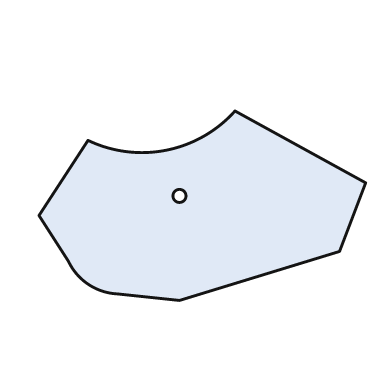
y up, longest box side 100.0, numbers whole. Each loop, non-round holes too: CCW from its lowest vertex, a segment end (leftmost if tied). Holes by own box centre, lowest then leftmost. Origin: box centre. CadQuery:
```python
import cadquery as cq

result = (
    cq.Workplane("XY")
    .moveTo(-7.0, -29.0)
    .lineTo(42.0, -14.0)
    .lineTo(50.0, 7.0)
    .lineTo(10.0, 29.0)
    .threePointArc((-11.0, 17.0), (-35.0, 20.0))
    .lineTo(-50.0, -3.0)
    .lineTo(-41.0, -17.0)
    .threePointArc((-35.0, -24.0), (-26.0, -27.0))
    .close()
    .moveTo(-7.0, 3.0)
    .circle(2.0)
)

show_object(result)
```